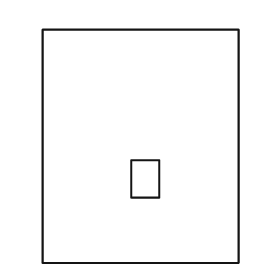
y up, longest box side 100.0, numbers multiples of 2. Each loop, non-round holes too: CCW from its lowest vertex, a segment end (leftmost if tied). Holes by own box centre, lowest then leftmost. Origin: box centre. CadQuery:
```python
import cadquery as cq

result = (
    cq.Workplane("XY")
    .moveTo(-42.0, -50.0)
    .lineTo(42.0, -50.0)
    .lineTo(42.0, 50.0)
    .lineTo(-42.0, 50.0)
    .close()
    .moveTo(-4.0, -22.0)
    .lineTo(8.0, -22.0)
    .lineTo(8.0, -6.0)
    .lineTo(-4.0, -6.0)
    .close()
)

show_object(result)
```